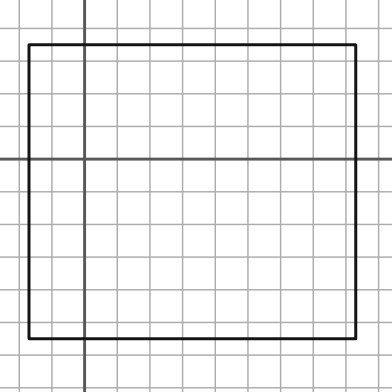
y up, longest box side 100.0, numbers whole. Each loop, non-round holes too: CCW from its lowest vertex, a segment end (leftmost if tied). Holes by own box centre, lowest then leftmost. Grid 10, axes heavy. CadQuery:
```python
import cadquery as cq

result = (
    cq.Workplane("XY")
    .moveTo(-17.0, -55.0)
    .lineTo(83.0, -55.0)
    .lineTo(83.0, 35.0)
    .lineTo(-17.0, 35.0)
    .close()
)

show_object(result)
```